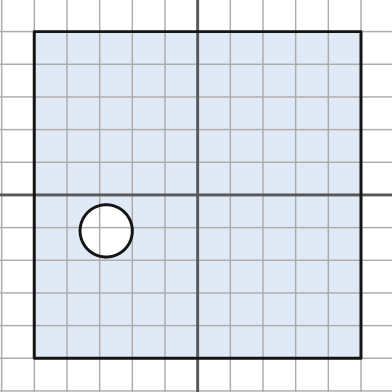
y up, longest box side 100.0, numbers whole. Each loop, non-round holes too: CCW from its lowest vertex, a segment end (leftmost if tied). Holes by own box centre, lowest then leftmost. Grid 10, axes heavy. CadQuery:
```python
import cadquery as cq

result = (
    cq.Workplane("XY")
    .moveTo(-50.0, -50.0)
    .lineTo(50.0, -50.0)
    .lineTo(50.0, 50.0)
    .lineTo(-50.0, 50.0)
    .close()
    .moveTo(-28.0, -11.0)
    .circle(8.0)
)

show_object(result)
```